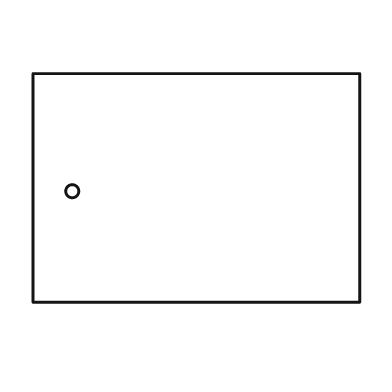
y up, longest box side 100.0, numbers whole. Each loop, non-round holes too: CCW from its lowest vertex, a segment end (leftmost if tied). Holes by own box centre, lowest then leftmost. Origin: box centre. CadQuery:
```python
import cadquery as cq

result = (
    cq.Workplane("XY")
    .moveTo(-50.0, -35.0)
    .lineTo(50.0, -35.0)
    .lineTo(50.0, 35.0)
    .lineTo(-50.0, 35.0)
    .close()
    .moveTo(-38.0, -1.0)
    .circle(2.0)
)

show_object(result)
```